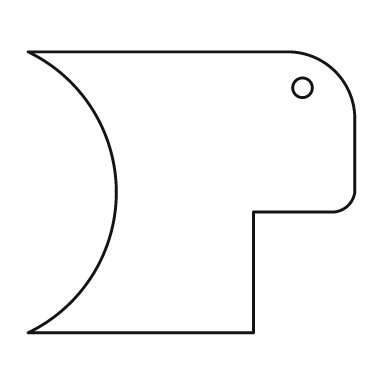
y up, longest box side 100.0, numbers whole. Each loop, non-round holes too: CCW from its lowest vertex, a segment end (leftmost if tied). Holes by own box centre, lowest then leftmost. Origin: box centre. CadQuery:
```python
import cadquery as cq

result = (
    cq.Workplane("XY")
    .moveTo(-50.0, -43.0)
    .lineTo(19.0, -43.0)
    .lineTo(19.0, -6.0)
    .lineTo(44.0, -6.0)
    .threePointArc((48.0, -4.0), (50.0, 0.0))
    .lineTo(50.0, 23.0)
    .threePointArc((44.0, 37.0), (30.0, 43.0))
    .lineTo(-50.0, 43.0)
    .threePointArc((-23.0, 0.0), (-50.0, -43.0))
    .close()
    .moveTo(34.0, 32.0)
    .circle(3.0)
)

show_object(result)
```